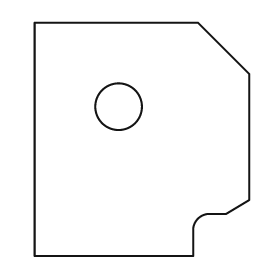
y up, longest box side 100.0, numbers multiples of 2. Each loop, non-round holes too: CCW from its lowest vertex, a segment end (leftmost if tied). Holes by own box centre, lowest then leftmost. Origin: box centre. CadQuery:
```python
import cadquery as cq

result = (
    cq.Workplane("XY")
    .moveTo(-46.0, -50.0)
    .lineTo(22.0, -50.0)
    .lineTo(22.0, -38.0)
    .threePointArc((24.0, -34.0), (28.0, -32.0))
    .lineTo(36.0, -32.0)
    .lineTo(46.0, -26.0)
    .lineTo(46.0, 28.0)
    .lineTo(24.0, 50.0)
    .lineTo(-46.0, 50.0)
    .close()
    .moveTo(-10.0, 14.0)
    .circle(10.0)
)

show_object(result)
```